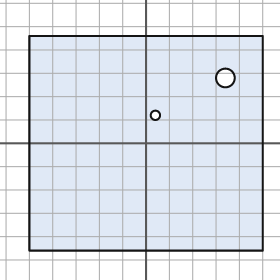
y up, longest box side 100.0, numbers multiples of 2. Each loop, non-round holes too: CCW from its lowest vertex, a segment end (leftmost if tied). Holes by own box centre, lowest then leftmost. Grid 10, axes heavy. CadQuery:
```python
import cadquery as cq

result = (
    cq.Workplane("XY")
    .moveTo(-50.0, -46.0)
    .lineTo(50.0, -46.0)
    .lineTo(50.0, 46.0)
    .lineTo(-50.0, 46.0)
    .close()
    .moveTo(4.0, 12.0)
    .circle(2.0)
    .moveTo(34.0, 28.0)
    .circle(4.0)
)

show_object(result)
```